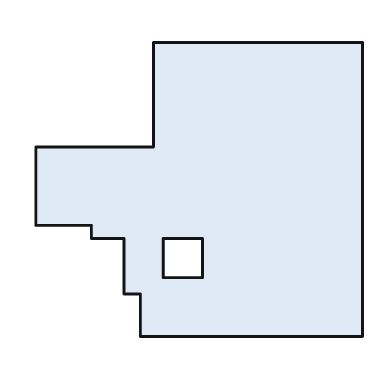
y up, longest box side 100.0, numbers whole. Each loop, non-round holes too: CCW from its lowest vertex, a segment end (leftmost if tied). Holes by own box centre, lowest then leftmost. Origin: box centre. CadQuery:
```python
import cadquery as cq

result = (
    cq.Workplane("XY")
    .moveTo(-18.0, -45.0)
    .lineTo(50.0, -45.0)
    .lineTo(50.0, 45.0)
    .lineTo(-14.0, 45.0)
    .lineTo(-14.0, 13.0)
    .lineTo(-50.0, 13.0)
    .lineTo(-50.0, -11.0)
    .lineTo(-33.0, -11.0)
    .lineTo(-33.0, -15.0)
    .lineTo(-23.0, -15.0)
    .lineTo(-23.0, -32.0)
    .lineTo(-18.0, -32.0)
    .close()
    .moveTo(-11.0, -27.0)
    .lineTo(1.0, -27.0)
    .lineTo(1.0, -15.0)
    .lineTo(-11.0, -15.0)
    .close()
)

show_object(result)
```